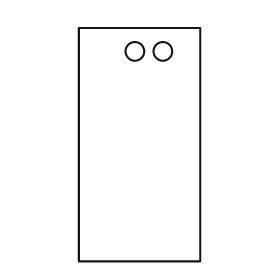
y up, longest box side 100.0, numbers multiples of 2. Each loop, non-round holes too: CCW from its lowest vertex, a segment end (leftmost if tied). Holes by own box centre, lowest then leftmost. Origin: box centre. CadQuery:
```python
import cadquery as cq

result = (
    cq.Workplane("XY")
    .moveTo(-26.0, -50.0)
    .lineTo(26.0, -50.0)
    .lineTo(26.0, 50.0)
    .lineTo(-26.0, 50.0)
    .close()
    .moveTo(-2.0, 40.0)
    .circle(4.0)
    .moveTo(10.0, 40.0)
    .circle(4.0)
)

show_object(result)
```